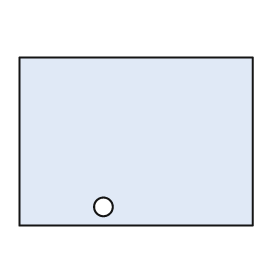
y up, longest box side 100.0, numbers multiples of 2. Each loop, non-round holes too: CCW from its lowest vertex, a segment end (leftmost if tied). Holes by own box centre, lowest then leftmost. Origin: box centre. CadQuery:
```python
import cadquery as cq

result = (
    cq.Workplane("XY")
    .moveTo(-50.0, -36.0)
    .lineTo(50.0, -36.0)
    .lineTo(50.0, 36.0)
    .lineTo(-50.0, 36.0)
    .close()
    .moveTo(-14.0, -28.0)
    .circle(4.0)
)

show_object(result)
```